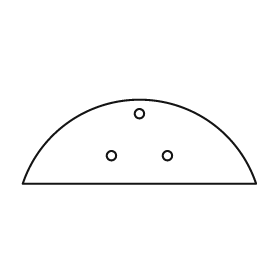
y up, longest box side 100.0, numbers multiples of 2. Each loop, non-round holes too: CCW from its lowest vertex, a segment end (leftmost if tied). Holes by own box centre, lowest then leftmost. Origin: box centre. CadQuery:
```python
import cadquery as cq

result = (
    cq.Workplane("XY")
    .moveTo(-50.0, -18.0)
    .lineTo(50.0, -18.0)
    .threePointArc((0.0, 18.0), (-50.0, -18.0))
    .close()
    .moveTo(-12.0, -6.0)
    .circle(2.0)
    .moveTo(12.0, -6.0)
    .circle(2.0)
    .moveTo(0.0, 12.0)
    .circle(2.0)
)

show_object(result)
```